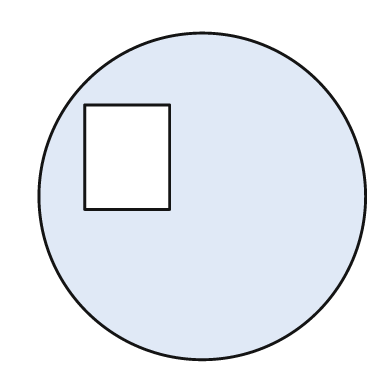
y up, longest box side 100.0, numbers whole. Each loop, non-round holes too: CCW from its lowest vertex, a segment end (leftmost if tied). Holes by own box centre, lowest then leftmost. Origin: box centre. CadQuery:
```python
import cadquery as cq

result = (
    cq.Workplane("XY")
    .moveTo(0.0, 0.0)
    .circle(50.0)
    .moveTo(-36.0, -4.0)
    .lineTo(-10.0, -4.0)
    .lineTo(-10.0, 28.0)
    .lineTo(-36.0, 28.0)
    .close()
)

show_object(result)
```